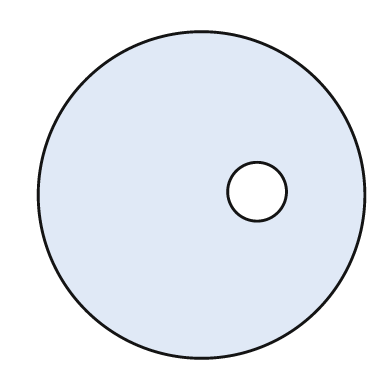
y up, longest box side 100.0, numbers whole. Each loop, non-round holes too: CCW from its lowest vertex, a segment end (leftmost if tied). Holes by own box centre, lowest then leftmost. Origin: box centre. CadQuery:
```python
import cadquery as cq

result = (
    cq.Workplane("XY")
    .moveTo(0.0, 0.0)
    .circle(50.0)
    .moveTo(17.0, 1.0)
    .circle(9.0)
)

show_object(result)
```